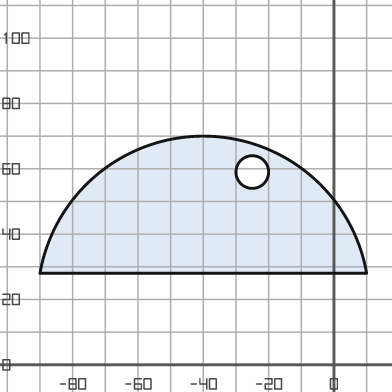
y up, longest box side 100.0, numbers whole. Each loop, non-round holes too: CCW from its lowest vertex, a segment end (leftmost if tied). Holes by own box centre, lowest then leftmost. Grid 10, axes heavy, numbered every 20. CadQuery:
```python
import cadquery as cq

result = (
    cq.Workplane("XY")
    .moveTo(-90.0, 28.0)
    .lineTo(10.0, 28.0)
    .threePointArc((-40.0, 70.0), (-90.0, 28.0))
    .close()
    .moveTo(-25.0, 59.0)
    .circle(5.0)
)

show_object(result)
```